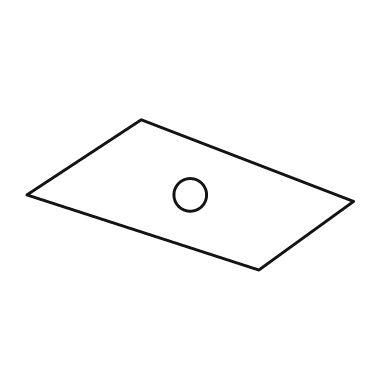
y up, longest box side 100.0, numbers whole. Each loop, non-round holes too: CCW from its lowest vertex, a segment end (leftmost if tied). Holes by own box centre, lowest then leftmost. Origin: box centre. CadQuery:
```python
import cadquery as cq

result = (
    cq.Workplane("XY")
    .moveTo(21.0, -23.0)
    .lineTo(50.0, -2.0)
    .lineTo(-15.0, 23.0)
    .lineTo(-50.0, 0.0)
    .close()
    .moveTo(0.0, 0.0)
    .circle(5.0)
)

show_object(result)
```